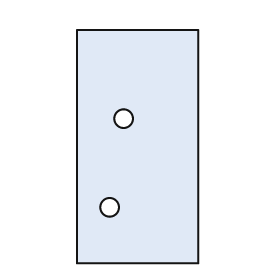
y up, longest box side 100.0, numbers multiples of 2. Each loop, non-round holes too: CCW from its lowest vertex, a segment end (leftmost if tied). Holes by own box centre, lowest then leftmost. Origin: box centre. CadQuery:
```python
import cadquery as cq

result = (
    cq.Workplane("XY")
    .moveTo(-26.0, -50.0)
    .lineTo(26.0, -50.0)
    .lineTo(26.0, 50.0)
    .lineTo(-26.0, 50.0)
    .close()
    .moveTo(-12.0, -26.0)
    .circle(4.0)
    .moveTo(-6.0, 12.0)
    .circle(4.0)
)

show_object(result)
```